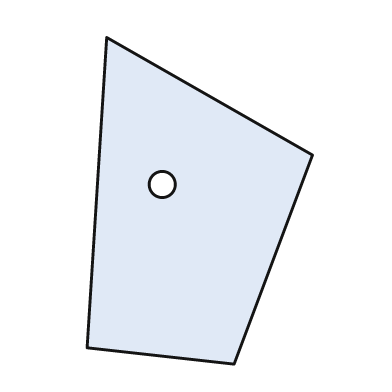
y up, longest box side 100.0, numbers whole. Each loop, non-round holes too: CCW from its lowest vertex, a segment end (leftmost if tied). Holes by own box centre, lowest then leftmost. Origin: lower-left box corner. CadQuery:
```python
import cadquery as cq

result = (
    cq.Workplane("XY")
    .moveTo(45.0, 0.0)
    .lineTo(69.0, 64.0)
    .lineTo(6.0, 100.0)
    .lineTo(0.0, 5.0)
    .close()
    .moveTo(23.0, 55.0)
    .circle(4.0)
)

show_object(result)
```